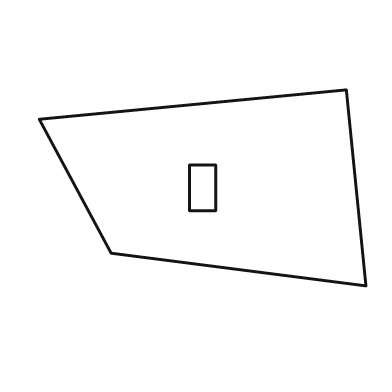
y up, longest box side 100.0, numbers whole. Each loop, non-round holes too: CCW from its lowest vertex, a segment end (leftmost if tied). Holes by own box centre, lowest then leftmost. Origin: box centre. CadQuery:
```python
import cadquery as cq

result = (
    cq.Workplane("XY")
    .moveTo(50.0, -30.0)
    .lineTo(44.0, 30.0)
    .lineTo(-50.0, 21.0)
    .lineTo(-28.0, -20.0)
    .close()
    .moveTo(-4.0, -7.0)
    .lineTo(4.0, -7.0)
    .lineTo(4.0, 7.0)
    .lineTo(-4.0, 7.0)
    .close()
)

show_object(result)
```